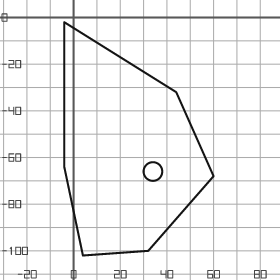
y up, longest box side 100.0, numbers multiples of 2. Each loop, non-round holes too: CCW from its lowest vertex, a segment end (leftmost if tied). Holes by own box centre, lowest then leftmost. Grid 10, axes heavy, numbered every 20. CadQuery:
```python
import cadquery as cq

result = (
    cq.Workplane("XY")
    .moveTo(4.0, -102.0)
    .lineTo(32.0, -100.0)
    .lineTo(60.0, -68.0)
    .lineTo(44.0, -32.0)
    .lineTo(-4.0, -2.0)
    .lineTo(-4.0, -64.0)
    .close()
    .moveTo(34.0, -66.0)
    .circle(4.0)
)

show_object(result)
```